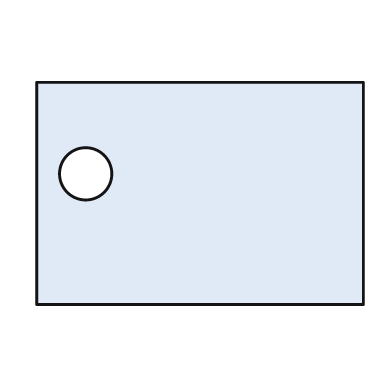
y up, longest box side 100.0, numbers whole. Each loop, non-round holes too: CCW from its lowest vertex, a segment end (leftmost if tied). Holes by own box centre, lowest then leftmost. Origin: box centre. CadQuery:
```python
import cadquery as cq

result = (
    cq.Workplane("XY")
    .moveTo(-50.0, -34.0)
    .lineTo(50.0, -34.0)
    .lineTo(50.0, 34.0)
    .lineTo(-50.0, 34.0)
    .close()
    .moveTo(-35.0, 6.0)
    .circle(8.0)
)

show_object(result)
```